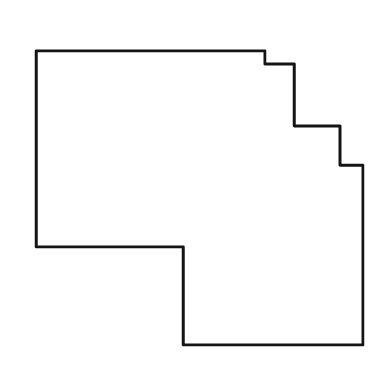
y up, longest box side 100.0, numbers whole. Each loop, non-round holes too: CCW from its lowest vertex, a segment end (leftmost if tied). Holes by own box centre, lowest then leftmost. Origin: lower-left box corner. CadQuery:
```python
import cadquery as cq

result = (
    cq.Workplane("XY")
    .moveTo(45.0, 0.0)
    .lineTo(100.0, 0.0)
    .lineTo(100.0, 55.0)
    .lineTo(93.0, 55.0)
    .lineTo(93.0, 67.0)
    .lineTo(79.0, 67.0)
    .lineTo(79.0, 86.0)
    .lineTo(70.0, 86.0)
    .lineTo(70.0, 90.0)
    .lineTo(0.0, 90.0)
    .lineTo(0.0, 30.0)
    .lineTo(45.0, 30.0)
    .close()
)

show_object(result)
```